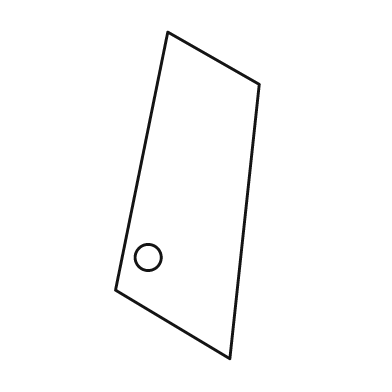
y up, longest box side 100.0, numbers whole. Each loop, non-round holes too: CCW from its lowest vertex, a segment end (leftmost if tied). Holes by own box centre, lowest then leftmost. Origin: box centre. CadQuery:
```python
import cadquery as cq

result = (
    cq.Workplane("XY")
    .moveTo(13.0, -50.0)
    .lineTo(22.0, 34.0)
    .lineTo(-6.0, 50.0)
    .lineTo(-22.0, -29.0)
    .close()
    .moveTo(-12.0, -19.0)
    .circle(4.0)
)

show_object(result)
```